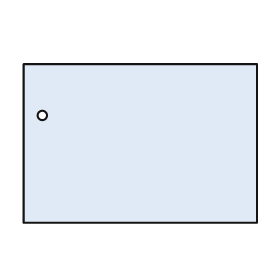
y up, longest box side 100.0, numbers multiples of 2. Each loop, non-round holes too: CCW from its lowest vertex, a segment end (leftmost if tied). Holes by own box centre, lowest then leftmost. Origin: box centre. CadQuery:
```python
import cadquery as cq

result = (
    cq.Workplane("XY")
    .moveTo(-50.0, -34.0)
    .lineTo(50.0, -34.0)
    .lineTo(50.0, 34.0)
    .lineTo(-50.0, 34.0)
    .close()
    .moveTo(-42.0, 12.0)
    .circle(2.0)
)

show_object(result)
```